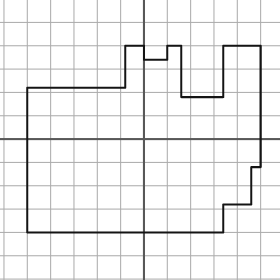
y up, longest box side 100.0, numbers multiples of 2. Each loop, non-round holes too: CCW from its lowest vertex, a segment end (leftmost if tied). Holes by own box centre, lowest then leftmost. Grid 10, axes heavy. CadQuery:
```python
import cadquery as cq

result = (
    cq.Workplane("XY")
    .moveTo(-50.0, -40.0)
    .lineTo(34.0, -40.0)
    .lineTo(34.0, -28.0)
    .lineTo(46.0, -28.0)
    .lineTo(46.0, -12.0)
    .lineTo(50.0, -12.0)
    .lineTo(50.0, 40.0)
    .lineTo(34.0, 40.0)
    .lineTo(34.0, 18.0)
    .lineTo(16.0, 18.0)
    .lineTo(16.0, 40.0)
    .lineTo(10.0, 40.0)
    .lineTo(10.0, 34.0)
    .lineTo(0.0, 34.0)
    .lineTo(0.0, 40.0)
    .lineTo(-8.0, 40.0)
    .lineTo(-8.0, 22.0)
    .lineTo(-50.0, 22.0)
    .close()
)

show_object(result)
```